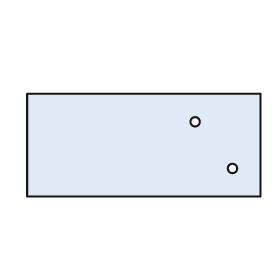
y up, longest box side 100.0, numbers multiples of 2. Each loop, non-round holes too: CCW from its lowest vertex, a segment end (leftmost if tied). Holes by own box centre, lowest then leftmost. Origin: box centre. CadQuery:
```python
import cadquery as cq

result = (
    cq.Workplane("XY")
    .moveTo(-50.0, -22.0)
    .lineTo(50.0, -22.0)
    .lineTo(50.0, 22.0)
    .lineTo(-50.0, 22.0)
    .close()
    .moveTo(38.0, -10.0)
    .circle(2.0)
    .moveTo(22.0, 10.0)
    .circle(2.0)
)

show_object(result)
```